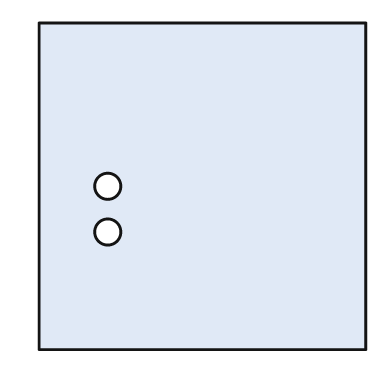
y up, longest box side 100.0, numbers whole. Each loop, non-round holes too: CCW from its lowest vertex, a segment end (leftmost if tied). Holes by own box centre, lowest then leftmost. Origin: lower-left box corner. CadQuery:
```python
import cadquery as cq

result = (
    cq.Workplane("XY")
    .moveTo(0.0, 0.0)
    .lineTo(100.0, 0.0)
    .lineTo(100.0, 100.0)
    .lineTo(0.0, 100.0)
    .close()
    .moveTo(21.0, 36.0)
    .circle(4.0)
    .moveTo(21.0, 50.0)
    .circle(4.0)
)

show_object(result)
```